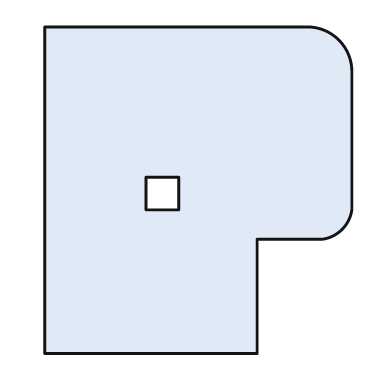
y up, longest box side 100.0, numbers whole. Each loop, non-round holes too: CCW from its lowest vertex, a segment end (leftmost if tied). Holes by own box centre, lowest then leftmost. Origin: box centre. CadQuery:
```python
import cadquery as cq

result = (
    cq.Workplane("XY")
    .moveTo(-47.0, -50.0)
    .lineTo(18.0, -50.0)
    .lineTo(18.0, -15.0)
    .lineTo(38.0, -15.0)
    .threePointArc((44.0, -12.0), (47.0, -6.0))
    .lineTo(47.0, 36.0)
    .threePointArc((43.0, 46.0), (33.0, 50.0))
    .lineTo(-47.0, 50.0)
    .close()
    .moveTo(-16.0, -6.0)
    .lineTo(-6.0, -6.0)
    .lineTo(-6.0, 4.0)
    .lineTo(-16.0, 4.0)
    .close()
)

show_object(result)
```